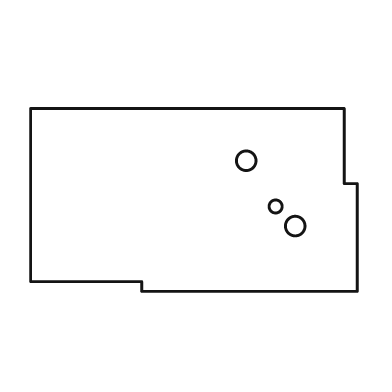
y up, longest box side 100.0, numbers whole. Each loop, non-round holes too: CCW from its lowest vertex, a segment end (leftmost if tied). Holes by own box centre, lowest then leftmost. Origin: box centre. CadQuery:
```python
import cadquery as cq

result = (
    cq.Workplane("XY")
    .moveTo(-16.0, -28.0)
    .lineTo(50.0, -28.0)
    .lineTo(50.0, 5.0)
    .lineTo(46.0, 5.0)
    .lineTo(46.0, 28.0)
    .lineTo(-50.0, 28.0)
    .lineTo(-50.0, -25.0)
    .lineTo(-16.0, -25.0)
    .close()
    .moveTo(31.0, -8.0)
    .circle(3.0)
    .moveTo(25.0, -2.0)
    .circle(2.0)
    .moveTo(16.0, 12.0)
    .circle(3.0)
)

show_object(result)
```